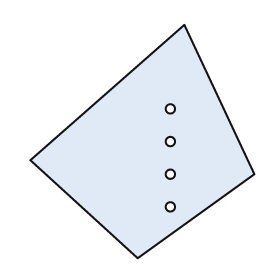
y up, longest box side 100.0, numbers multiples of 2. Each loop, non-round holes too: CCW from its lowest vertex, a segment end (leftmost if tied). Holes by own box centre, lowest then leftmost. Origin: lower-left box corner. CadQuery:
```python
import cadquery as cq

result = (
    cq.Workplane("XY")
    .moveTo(46.0, 0.0)
    .lineTo(96.0, 36.0)
    .lineTo(66.0, 100.0)
    .lineTo(0.0, 42.0)
    .close()
    .moveTo(60.0, 22.0)
    .circle(2.0)
    .moveTo(60.0, 36.0)
    .circle(2.0)
    .moveTo(60.0, 50.0)
    .circle(2.0)
    .moveTo(60.0, 64.0)
    .circle(2.0)
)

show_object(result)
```